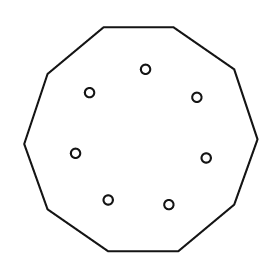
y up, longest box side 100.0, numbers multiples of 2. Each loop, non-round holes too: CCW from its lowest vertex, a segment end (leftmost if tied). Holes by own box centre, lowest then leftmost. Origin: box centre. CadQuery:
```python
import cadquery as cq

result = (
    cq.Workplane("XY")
    .moveTo(-14.0, -48.0)
    .lineTo(16.0, -48.0)
    .lineTo(40.0, -28.0)
    .lineTo(50.0, 0.0)
    .lineTo(40.0, 30.0)
    .lineTo(14.0, 48.0)
    .lineTo(-16.0, 48.0)
    .lineTo(-40.0, 28.0)
    .lineTo(-50.0, -2.0)
    .lineTo(-40.0, -30.0)
    .close()
    .moveTo(12.0, -28.0)
    .circle(2.0)
    .moveTo(-14.0, -26.0)
    .circle(2.0)
    .moveTo(28.0, -8.0)
    .circle(2.0)
    .moveTo(-28.0, -6.0)
    .circle(2.0)
    .moveTo(24.0, 18.0)
    .circle(2.0)
    .moveTo(-22.0, 20.0)
    .circle(2.0)
    .moveTo(2.0, 30.0)
    .circle(2.0)
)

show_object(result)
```